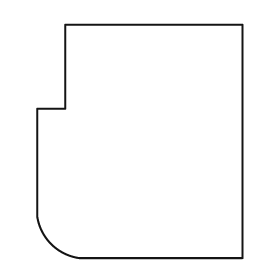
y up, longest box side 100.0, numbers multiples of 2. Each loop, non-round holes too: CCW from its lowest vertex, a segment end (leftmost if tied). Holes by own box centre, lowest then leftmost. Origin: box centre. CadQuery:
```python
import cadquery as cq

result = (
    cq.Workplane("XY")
    .moveTo(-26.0, -50.0)
    .lineTo(44.0, -50.0)
    .lineTo(44.0, 50.0)
    .lineTo(-32.0, 50.0)
    .lineTo(-32.0, 14.0)
    .lineTo(-44.0, 14.0)
    .lineTo(-44.0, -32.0)
    .threePointArc((-38.0, -44.0), (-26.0, -50.0))
    .close()
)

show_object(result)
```